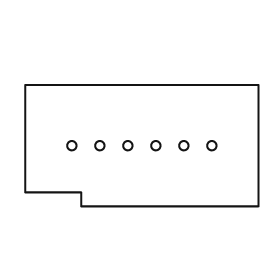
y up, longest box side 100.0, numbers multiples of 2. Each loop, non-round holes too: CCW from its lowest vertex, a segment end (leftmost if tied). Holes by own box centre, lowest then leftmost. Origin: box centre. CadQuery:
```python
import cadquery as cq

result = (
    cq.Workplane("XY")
    .moveTo(-26.0, -26.0)
    .lineTo(50.0, -26.0)
    .lineTo(50.0, 26.0)
    .lineTo(-50.0, 26.0)
    .lineTo(-50.0, -20.0)
    .lineTo(-26.0, -20.0)
    .close()
    .moveTo(-30.0, 0.0)
    .circle(2.0)
    .moveTo(-18.0, 0.0)
    .circle(2.0)
    .moveTo(-6.0, 0.0)
    .circle(2.0)
    .moveTo(6.0, 0.0)
    .circle(2.0)
    .moveTo(18.0, 0.0)
    .circle(2.0)
    .moveTo(30.0, 0.0)
    .circle(2.0)
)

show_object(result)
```